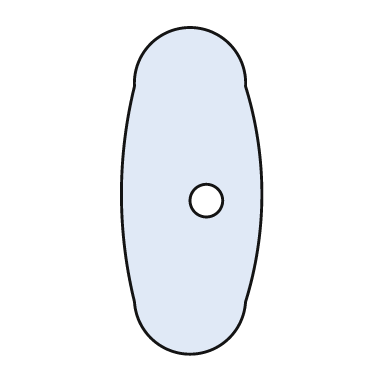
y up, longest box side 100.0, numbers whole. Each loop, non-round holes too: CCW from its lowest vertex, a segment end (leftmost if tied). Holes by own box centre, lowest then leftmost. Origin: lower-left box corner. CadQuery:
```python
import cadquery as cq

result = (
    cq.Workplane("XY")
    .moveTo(4.0, 16.0)
    .threePointArc((21.0, 0.0), (38.0, 16.0))
    .threePointArc((43.0, 49.0), (38.0, 82.0))
    .threePointArc((21.0, 100.0), (4.0, 82.0))
    .threePointArc((0.0, 49.0), (4.0, 16.0))
    .close()
    .moveTo(26.0, 47.0)
    .circle(5.0)
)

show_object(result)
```